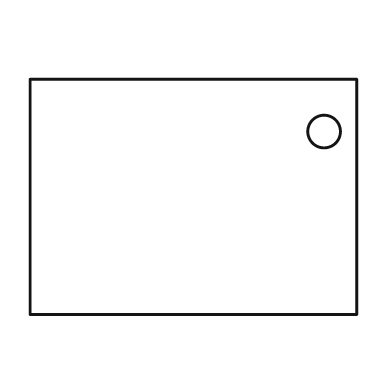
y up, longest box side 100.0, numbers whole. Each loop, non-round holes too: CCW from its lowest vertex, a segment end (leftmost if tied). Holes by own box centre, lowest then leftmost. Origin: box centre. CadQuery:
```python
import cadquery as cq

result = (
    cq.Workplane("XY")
    .moveTo(-50.0, -36.0)
    .lineTo(50.0, -36.0)
    .lineTo(50.0, 36.0)
    .lineTo(-50.0, 36.0)
    .close()
    .moveTo(40.0, 20.0)
    .circle(5.0)
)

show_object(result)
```